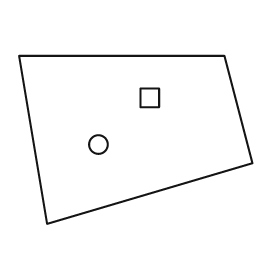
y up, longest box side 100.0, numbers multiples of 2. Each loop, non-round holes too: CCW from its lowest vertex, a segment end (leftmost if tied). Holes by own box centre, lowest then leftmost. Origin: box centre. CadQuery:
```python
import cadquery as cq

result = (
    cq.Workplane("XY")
    .moveTo(-38.0, -36.0)
    .lineTo(50.0, -10.0)
    .lineTo(38.0, 36.0)
    .lineTo(-50.0, 36.0)
    .close()
    .moveTo(-16.0, -2.0)
    .circle(4.0)
    .moveTo(2.0, 14.0)
    .lineTo(10.0, 14.0)
    .lineTo(10.0, 22.0)
    .lineTo(2.0, 22.0)
    .close()
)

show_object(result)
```